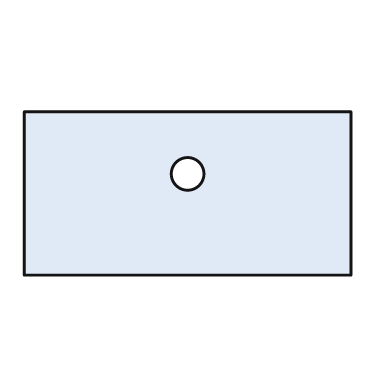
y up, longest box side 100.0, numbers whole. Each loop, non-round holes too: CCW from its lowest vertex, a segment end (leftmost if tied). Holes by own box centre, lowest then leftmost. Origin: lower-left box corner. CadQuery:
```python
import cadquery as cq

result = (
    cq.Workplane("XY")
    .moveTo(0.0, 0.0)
    .lineTo(100.0, 0.0)
    .lineTo(100.0, 50.0)
    .lineTo(0.0, 50.0)
    .close()
    .moveTo(50.0, 31.0)
    .circle(5.0)
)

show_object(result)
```